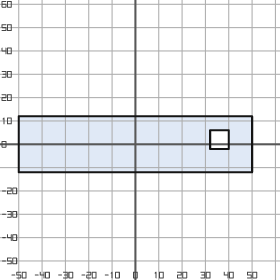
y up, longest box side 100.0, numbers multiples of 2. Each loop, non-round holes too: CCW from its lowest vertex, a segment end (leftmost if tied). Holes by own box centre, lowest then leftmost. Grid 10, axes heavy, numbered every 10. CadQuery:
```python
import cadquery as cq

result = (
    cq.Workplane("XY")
    .moveTo(-50.0, -12.0)
    .lineTo(50.0, -12.0)
    .lineTo(50.0, 12.0)
    .lineTo(-50.0, 12.0)
    .close()
    .moveTo(32.0, -2.0)
    .lineTo(40.0, -2.0)
    .lineTo(40.0, 6.0)
    .lineTo(32.0, 6.0)
    .close()
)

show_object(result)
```